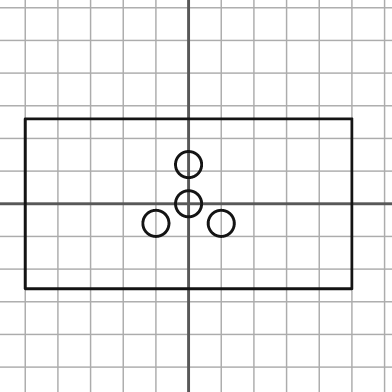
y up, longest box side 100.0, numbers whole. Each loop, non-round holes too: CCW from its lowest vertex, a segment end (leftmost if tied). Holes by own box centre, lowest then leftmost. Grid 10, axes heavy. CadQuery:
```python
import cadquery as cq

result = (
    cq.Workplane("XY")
    .moveTo(-50.0, -26.0)
    .lineTo(50.0, -26.0)
    .lineTo(50.0, 26.0)
    .lineTo(-50.0, 26.0)
    .close()
    .moveTo(-10.0, -6.0)
    .circle(4.0)
    .moveTo(10.0, -6.0)
    .circle(4.0)
    .moveTo(0.0, 0.0)
    .circle(4.0)
    .moveTo(0.0, 12.0)
    .circle(4.0)
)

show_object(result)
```